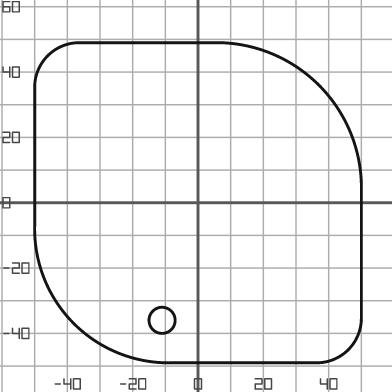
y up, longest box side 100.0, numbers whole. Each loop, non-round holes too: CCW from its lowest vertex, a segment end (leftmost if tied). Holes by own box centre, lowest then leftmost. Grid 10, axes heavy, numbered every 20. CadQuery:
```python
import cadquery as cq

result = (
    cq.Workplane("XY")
    .moveTo(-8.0, -49.0)
    .lineTo(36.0, -49.0)
    .threePointArc((46.0, -45.0), (50.0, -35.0))
    .lineTo(50.0, 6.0)
    .threePointArc((37.0, 36.0), (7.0, 49.0))
    .lineTo(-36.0, 49.0)
    .threePointArc((-46.0, 45.0), (-50.0, 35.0))
    .lineTo(-50.0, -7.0)
    .threePointArc((-38.0, -37.0), (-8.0, -49.0))
    .close()
    .moveTo(-11.0, -36.0)
    .circle(4.0)
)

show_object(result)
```